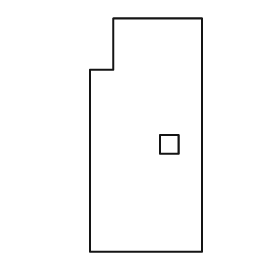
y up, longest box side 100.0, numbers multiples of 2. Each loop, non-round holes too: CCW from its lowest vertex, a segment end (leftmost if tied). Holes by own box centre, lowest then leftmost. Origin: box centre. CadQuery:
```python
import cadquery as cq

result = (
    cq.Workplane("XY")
    .moveTo(-24.0, -50.0)
    .lineTo(24.0, -50.0)
    .lineTo(24.0, 50.0)
    .lineTo(-14.0, 50.0)
    .lineTo(-14.0, 28.0)
    .lineTo(-24.0, 28.0)
    .close()
    .moveTo(6.0, -8.0)
    .lineTo(14.0, -8.0)
    .lineTo(14.0, 0.0)
    .lineTo(6.0, 0.0)
    .close()
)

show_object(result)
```